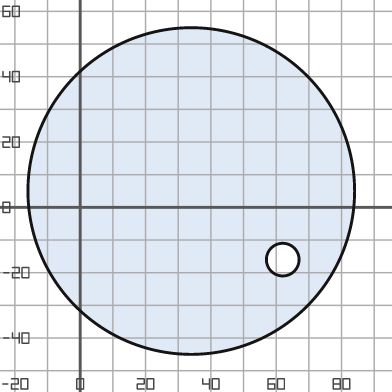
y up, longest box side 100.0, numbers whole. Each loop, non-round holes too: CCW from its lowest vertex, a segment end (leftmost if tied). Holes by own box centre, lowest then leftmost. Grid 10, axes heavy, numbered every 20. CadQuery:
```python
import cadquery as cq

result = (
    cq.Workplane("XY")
    .moveTo(34.0, 5.0)
    .circle(50.0)
    .moveTo(62.0, -16.0)
    .circle(5.0)
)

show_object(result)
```